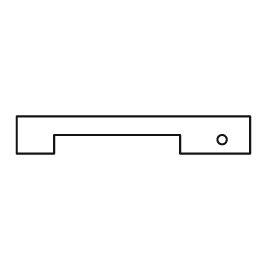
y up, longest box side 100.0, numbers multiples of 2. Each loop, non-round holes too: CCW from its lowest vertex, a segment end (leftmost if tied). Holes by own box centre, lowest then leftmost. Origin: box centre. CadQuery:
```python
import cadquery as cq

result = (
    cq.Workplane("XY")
    .moveTo(-50.0, -8.0)
    .lineTo(-34.0, -8.0)
    .lineTo(-34.0, 0.0)
    .lineTo(20.0, 0.0)
    .lineTo(20.0, -8.0)
    .lineTo(50.0, -8.0)
    .lineTo(50.0, 8.0)
    .lineTo(-50.0, 8.0)
    .close()
    .moveTo(38.0, -2.0)
    .circle(2.0)
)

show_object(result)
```